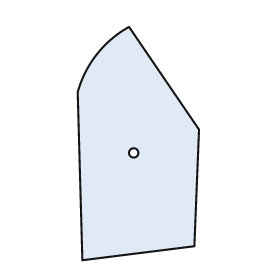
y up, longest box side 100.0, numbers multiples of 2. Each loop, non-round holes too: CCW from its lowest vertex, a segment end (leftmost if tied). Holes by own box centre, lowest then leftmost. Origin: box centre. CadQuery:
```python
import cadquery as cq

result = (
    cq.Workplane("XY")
    .moveTo(-24.0, -50.0)
    .lineTo(24.0, -44.0)
    .lineTo(26.0, 6.0)
    .lineTo(-4.0, 50.0)
    .threePointArc((-18.0, 38.0), (-26.0, 22.0))
    .close()
    .moveTo(-2.0, -4.0)
    .circle(2.0)
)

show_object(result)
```